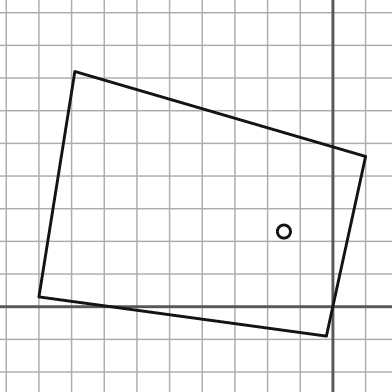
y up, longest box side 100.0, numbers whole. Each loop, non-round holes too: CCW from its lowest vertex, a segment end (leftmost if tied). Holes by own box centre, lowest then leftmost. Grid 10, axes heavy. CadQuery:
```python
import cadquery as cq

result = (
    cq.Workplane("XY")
    .moveTo(-2.0, -9.0)
    .lineTo(10.0, 46.0)
    .lineTo(-79.0, 72.0)
    .lineTo(-90.0, 3.0)
    .close()
    .moveTo(-15.0, 23.0)
    .circle(2.0)
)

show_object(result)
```